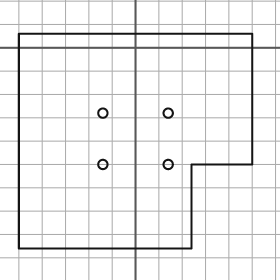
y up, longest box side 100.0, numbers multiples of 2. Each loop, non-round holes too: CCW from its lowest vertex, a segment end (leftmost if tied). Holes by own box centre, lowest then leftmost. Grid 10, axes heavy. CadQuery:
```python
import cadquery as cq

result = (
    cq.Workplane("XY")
    .moveTo(-50.0, -86.0)
    .lineTo(24.0, -86.0)
    .lineTo(24.0, -50.0)
    .lineTo(50.0, -50.0)
    .lineTo(50.0, 6.0)
    .lineTo(-50.0, 6.0)
    .close()
    .moveTo(-14.0, -50.0)
    .circle(2.0)
    .moveTo(14.0, -50.0)
    .circle(2.0)
    .moveTo(-14.0, -28.0)
    .circle(2.0)
    .moveTo(14.0, -28.0)
    .circle(2.0)
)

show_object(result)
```